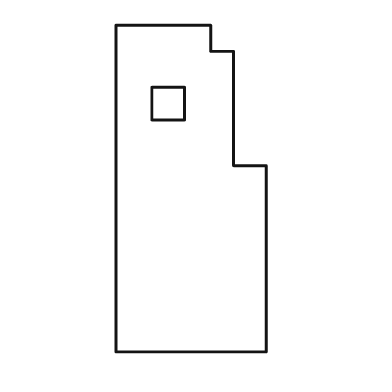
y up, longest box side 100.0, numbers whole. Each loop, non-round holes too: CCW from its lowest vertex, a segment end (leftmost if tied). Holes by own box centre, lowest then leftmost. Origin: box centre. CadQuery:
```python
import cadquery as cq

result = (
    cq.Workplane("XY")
    .moveTo(-23.0, -50.0)
    .lineTo(23.0, -50.0)
    .lineTo(23.0, 7.0)
    .lineTo(13.0, 7.0)
    .lineTo(13.0, 42.0)
    .lineTo(6.0, 42.0)
    .lineTo(6.0, 50.0)
    .lineTo(-23.0, 50.0)
    .close()
    .moveTo(-12.0, 21.0)
    .lineTo(-2.0, 21.0)
    .lineTo(-2.0, 31.0)
    .lineTo(-12.0, 31.0)
    .close()
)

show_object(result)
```